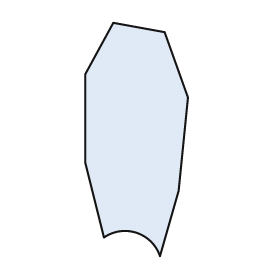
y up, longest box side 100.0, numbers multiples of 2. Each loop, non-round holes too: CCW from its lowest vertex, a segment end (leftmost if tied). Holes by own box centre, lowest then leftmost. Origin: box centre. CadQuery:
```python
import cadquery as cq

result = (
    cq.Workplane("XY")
    .moveTo(10.0, -50.0)
    .lineTo(18.0, -22.0)
    .lineTo(22.0, 18.0)
    .lineTo(12.0, 46.0)
    .lineTo(-10.0, 50.0)
    .lineTo(-22.0, 28.0)
    .lineTo(-22.0, -10.0)
    .lineTo(-14.0, -42.0)
    .threePointArc((0.0, -40.0), (10.0, -50.0))
    .close()
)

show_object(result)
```